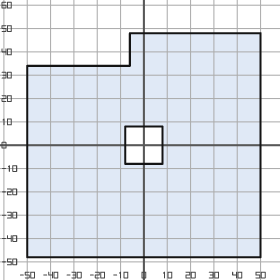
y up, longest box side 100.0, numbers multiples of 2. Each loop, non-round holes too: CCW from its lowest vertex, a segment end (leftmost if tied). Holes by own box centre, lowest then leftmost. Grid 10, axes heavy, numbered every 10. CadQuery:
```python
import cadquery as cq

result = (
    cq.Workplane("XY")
    .moveTo(-50.0, -48.0)
    .lineTo(50.0, -48.0)
    .lineTo(50.0, 48.0)
    .lineTo(-6.0, 48.0)
    .lineTo(-6.0, 34.0)
    .lineTo(-50.0, 34.0)
    .close()
    .moveTo(-8.0, -8.0)
    .lineTo(8.0, -8.0)
    .lineTo(8.0, 8.0)
    .lineTo(-8.0, 8.0)
    .close()
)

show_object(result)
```